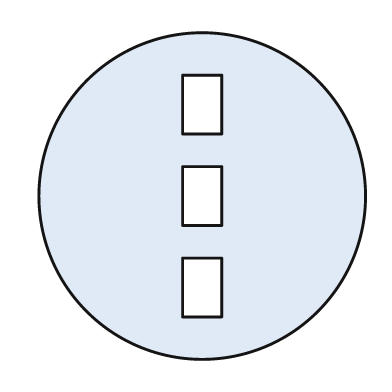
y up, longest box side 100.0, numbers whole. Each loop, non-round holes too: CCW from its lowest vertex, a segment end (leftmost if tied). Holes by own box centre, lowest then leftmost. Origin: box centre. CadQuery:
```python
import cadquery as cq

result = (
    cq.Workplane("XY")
    .moveTo(0.0, 0.0)
    .circle(50.0)
    .moveTo(-6.0, -37.0)
    .lineTo(6.0, -37.0)
    .lineTo(6.0, -19.0)
    .lineTo(-6.0, -19.0)
    .close()
    .moveTo(-6.0, -9.0)
    .lineTo(6.0, -9.0)
    .lineTo(6.0, 9.0)
    .lineTo(-6.0, 9.0)
    .close()
    .moveTo(-6.0, 19.0)
    .lineTo(6.0, 19.0)
    .lineTo(6.0, 37.0)
    .lineTo(-6.0, 37.0)
    .close()
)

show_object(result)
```